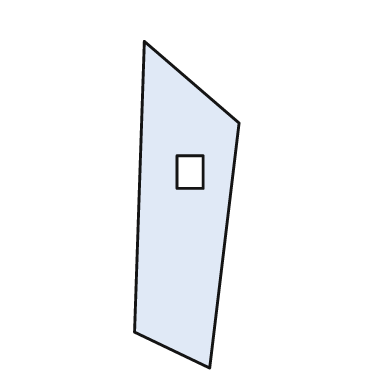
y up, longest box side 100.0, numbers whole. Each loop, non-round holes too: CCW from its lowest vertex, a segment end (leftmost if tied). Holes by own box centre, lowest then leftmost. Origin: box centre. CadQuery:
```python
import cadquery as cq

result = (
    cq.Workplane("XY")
    .moveTo(7.0, -50.0)
    .lineTo(16.0, 25.0)
    .lineTo(-13.0, 50.0)
    .lineTo(-16.0, -39.0)
    .close()
    .moveTo(-3.0, 5.0)
    .lineTo(5.0, 5.0)
    .lineTo(5.0, 15.0)
    .lineTo(-3.0, 15.0)
    .close()
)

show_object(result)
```